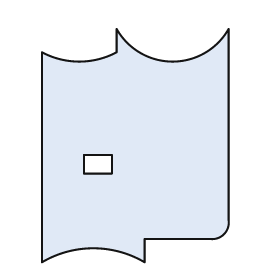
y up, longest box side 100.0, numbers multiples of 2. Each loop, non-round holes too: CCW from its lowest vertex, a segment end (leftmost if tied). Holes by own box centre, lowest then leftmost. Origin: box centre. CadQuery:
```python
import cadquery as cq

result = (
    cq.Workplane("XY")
    .moveTo(-40.0, -50.0)
    .threePointArc((-18.0, -44.0), (4.0, -50.0))
    .lineTo(4.0, -40.0)
    .lineTo(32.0, -40.0)
    .threePointArc((38.0, -38.0), (40.0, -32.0))
    .lineTo(40.0, 50.0)
    .threePointArc((16.0, 36.0), (-8.0, 50.0))
    .lineTo(-8.0, 40.0)
    .threePointArc((-24.0, 36.0), (-40.0, 40.0))
    .close()
    .moveTo(-22.0, -12.0)
    .lineTo(-10.0, -12.0)
    .lineTo(-10.0, -4.0)
    .lineTo(-22.0, -4.0)
    .close()
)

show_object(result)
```